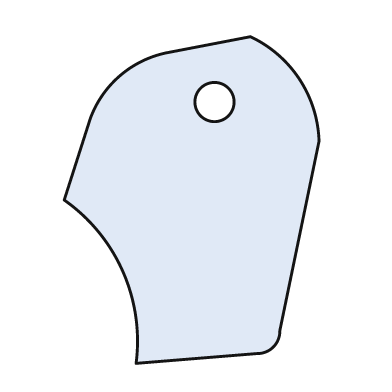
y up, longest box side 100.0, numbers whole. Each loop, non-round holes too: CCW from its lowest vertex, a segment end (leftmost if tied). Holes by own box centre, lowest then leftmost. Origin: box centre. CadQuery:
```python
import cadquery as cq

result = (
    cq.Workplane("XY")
    .moveTo(-17.0, -50.0)
    .lineTo(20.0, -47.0)
    .threePointArc((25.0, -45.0), (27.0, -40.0))
    .lineTo(39.0, 18.0)
    .threePointArc((33.0, 37.0), (18.0, 50.0))
    .lineTo(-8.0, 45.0)
    .threePointArc((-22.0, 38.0), (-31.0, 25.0))
    .lineTo(-39.0, 0.0)
    .threePointArc((-21.0, -22.0), (-17.0, -50.0))
    .close()
    .moveTo(7.0, 30.0)
    .circle(6.0)
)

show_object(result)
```